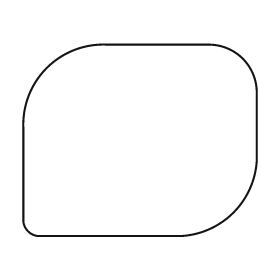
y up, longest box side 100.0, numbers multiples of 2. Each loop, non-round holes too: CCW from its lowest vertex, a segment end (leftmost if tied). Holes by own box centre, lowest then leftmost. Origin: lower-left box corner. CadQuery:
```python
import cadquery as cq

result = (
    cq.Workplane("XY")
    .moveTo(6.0, 0.0)
    .lineTo(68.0, 0.0)
    .threePointArc((90.0, 10.0), (100.0, 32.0))
    .lineTo(100.0, 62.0)
    .threePointArc((94.0, 76.0), (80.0, 82.0))
    .lineTo(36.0, 82.0)
    .threePointArc((10.0, 72.0), (0.0, 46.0))
    .lineTo(0.0, 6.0)
    .threePointArc((2.0, 2.0), (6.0, 0.0))
    .close()
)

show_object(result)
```